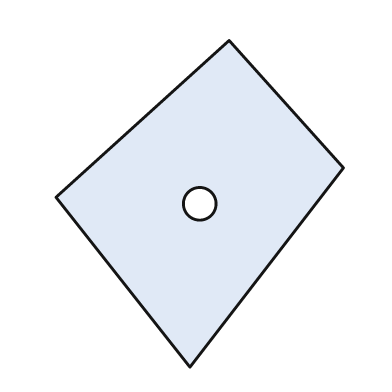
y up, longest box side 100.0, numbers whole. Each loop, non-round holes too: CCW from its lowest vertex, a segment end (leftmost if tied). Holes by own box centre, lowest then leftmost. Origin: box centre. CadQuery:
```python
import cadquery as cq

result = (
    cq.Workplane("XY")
    .moveTo(-3.0, -50.0)
    .lineTo(44.0, 11.0)
    .lineTo(9.0, 50.0)
    .lineTo(-44.0, 2.0)
    .close()
    .moveTo(0.0, 0.0)
    .circle(5.0)
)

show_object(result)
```